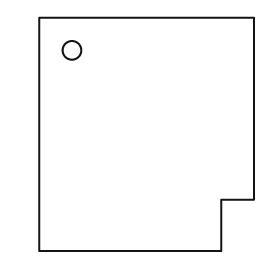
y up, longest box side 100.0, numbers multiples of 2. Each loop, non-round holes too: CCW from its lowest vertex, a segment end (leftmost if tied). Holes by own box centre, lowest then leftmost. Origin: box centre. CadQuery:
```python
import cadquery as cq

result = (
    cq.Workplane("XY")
    .moveTo(-46.0, -50.0)
    .lineTo(32.0, -50.0)
    .lineTo(32.0, -28.0)
    .lineTo(46.0, -28.0)
    .lineTo(46.0, 50.0)
    .lineTo(-46.0, 50.0)
    .close()
    .moveTo(-32.0, 36.0)
    .circle(4.0)
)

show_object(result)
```